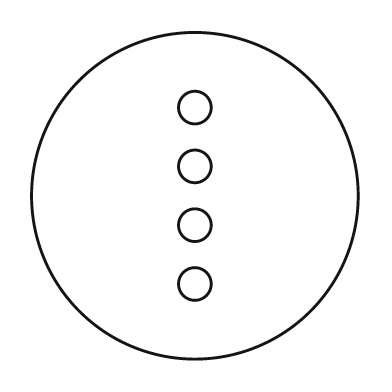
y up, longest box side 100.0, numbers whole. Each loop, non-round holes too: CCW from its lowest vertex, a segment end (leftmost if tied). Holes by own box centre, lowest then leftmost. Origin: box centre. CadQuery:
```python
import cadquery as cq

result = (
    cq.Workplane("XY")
    .moveTo(0.0, 0.0)
    .circle(50.0)
    .moveTo(0.0, -27.0)
    .circle(5.0)
    .moveTo(0.0, -9.0)
    .circle(5.0)
    .moveTo(0.0, 9.0)
    .circle(5.0)
    .moveTo(0.0, 27.0)
    .circle(5.0)
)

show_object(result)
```